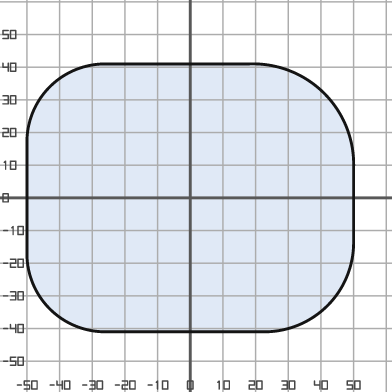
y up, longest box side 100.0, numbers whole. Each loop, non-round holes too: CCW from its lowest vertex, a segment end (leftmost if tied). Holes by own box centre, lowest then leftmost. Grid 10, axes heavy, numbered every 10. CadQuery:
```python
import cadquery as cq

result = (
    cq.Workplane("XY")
    .moveTo(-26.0, -41.0)
    .lineTo(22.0, -41.0)
    .threePointArc((42.0, -33.0), (50.0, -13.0))
    .lineTo(50.0, 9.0)
    .threePointArc((41.0, 32.0), (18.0, 41.0))
    .lineTo(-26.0, 41.0)
    .threePointArc((-43.0, 34.0), (-50.0, 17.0))
    .lineTo(-50.0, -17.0)
    .threePointArc((-43.0, -34.0), (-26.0, -41.0))
    .close()
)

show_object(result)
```